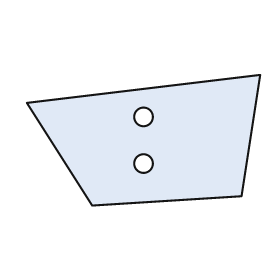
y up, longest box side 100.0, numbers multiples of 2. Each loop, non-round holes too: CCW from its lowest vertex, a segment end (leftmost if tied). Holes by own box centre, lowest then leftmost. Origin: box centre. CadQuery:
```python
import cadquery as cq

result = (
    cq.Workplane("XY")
    .moveTo(-22.0, -28.0)
    .lineTo(42.0, -24.0)
    .lineTo(50.0, 28.0)
    .lineTo(-50.0, 16.0)
    .close()
    .moveTo(0.0, -10.0)
    .circle(4.0)
    .moveTo(0.0, 10.0)
    .circle(4.0)
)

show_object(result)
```